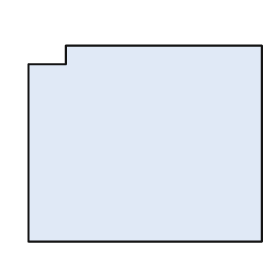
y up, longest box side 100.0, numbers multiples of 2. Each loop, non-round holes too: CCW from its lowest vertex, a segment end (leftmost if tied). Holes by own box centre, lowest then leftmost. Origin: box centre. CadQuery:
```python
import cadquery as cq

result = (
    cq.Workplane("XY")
    .moveTo(-50.0, -42.0)
    .lineTo(50.0, -42.0)
    .lineTo(50.0, 42.0)
    .lineTo(-34.0, 42.0)
    .lineTo(-34.0, 34.0)
    .lineTo(-50.0, 34.0)
    .close()
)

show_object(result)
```